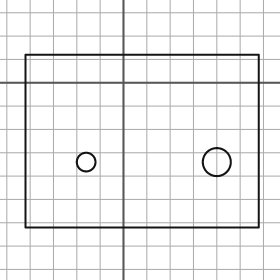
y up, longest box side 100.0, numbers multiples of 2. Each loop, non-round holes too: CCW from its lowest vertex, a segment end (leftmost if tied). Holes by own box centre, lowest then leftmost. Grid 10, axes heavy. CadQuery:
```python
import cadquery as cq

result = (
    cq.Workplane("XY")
    .moveTo(-42.0, -62.0)
    .lineTo(58.0, -62.0)
    .lineTo(58.0, 12.0)
    .lineTo(-42.0, 12.0)
    .close()
    .moveTo(-16.0, -34.0)
    .circle(4.0)
    .moveTo(40.0, -34.0)
    .circle(6.0)
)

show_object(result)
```